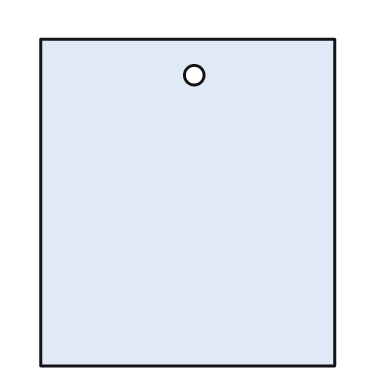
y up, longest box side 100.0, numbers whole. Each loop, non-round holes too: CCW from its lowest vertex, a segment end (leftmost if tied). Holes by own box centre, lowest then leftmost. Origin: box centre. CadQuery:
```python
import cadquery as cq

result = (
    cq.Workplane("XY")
    .moveTo(-45.0, -50.0)
    .lineTo(45.0, -50.0)
    .lineTo(45.0, 50.0)
    .lineTo(-45.0, 50.0)
    .close()
    .moveTo(2.0, 39.0)
    .circle(3.0)
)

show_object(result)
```